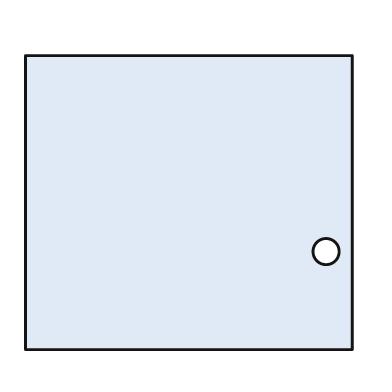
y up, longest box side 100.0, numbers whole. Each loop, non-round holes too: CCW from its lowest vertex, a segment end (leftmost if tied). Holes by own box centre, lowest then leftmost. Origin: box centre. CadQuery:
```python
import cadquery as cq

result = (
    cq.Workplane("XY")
    .moveTo(-50.0, -45.0)
    .lineTo(50.0, -45.0)
    .lineTo(50.0, 45.0)
    .lineTo(-50.0, 45.0)
    .close()
    .moveTo(42.0, -15.0)
    .circle(4.0)
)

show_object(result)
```